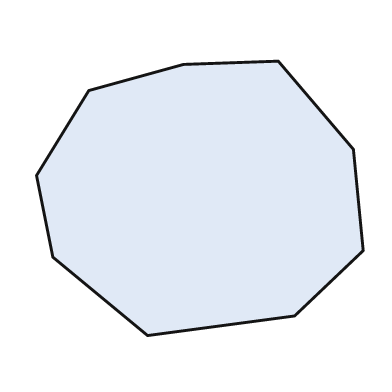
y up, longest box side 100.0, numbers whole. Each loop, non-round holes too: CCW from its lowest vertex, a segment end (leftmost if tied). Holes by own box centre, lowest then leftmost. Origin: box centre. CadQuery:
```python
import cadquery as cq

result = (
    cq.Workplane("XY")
    .moveTo(-16.0, -42.0)
    .lineTo(29.0, -36.0)
    .lineTo(50.0, -16.0)
    .lineTo(47.0, 15.0)
    .lineTo(24.0, 42.0)
    .lineTo(-5.0, 41.0)
    .lineTo(-34.0, 33.0)
    .lineTo(-50.0, 7.0)
    .lineTo(-45.0, -18.0)
    .close()
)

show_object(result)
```